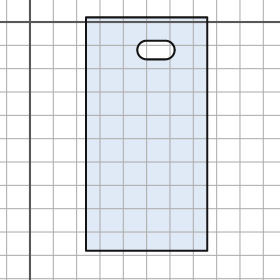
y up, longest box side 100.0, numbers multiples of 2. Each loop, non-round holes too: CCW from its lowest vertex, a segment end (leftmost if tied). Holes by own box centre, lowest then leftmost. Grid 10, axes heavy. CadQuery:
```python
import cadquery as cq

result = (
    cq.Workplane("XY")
    .moveTo(24.0, -98.0)
    .lineTo(76.0, -98.0)
    .lineTo(76.0, 2.0)
    .lineTo(24.0, 2.0)
    .close()
    .moveTo(50.0, -16.0)
    .lineTo(58.0, -16.0)
    .threePointArc((62.0, -12.0), (58.0, -8.0))
    .lineTo(50.0, -8.0)
    .threePointArc((46.0, -12.0), (50.0, -16.0))
    .close()
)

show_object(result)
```